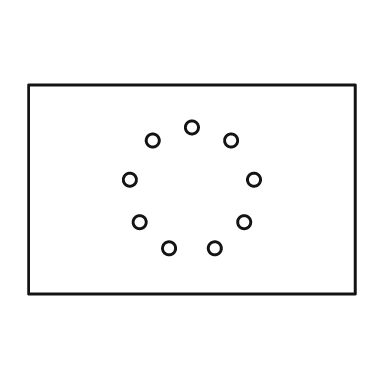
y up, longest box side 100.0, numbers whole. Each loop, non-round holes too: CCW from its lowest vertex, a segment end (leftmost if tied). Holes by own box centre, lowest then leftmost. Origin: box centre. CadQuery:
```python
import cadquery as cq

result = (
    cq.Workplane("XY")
    .moveTo(-50.0, -32.0)
    .lineTo(50.0, -32.0)
    .lineTo(50.0, 32.0)
    .lineTo(-50.0, 32.0)
    .close()
    .moveTo(-7.0, -18.0)
    .circle(2.0)
    .moveTo(7.0, -18.0)
    .circle(2.0)
    .moveTo(-16.0, -10.0)
    .circle(2.0)
    .moveTo(16.0, -10.0)
    .circle(2.0)
    .moveTo(-19.0, 3.0)
    .circle(2.0)
    .moveTo(19.0, 3.0)
    .circle(2.0)
    .moveTo(-12.0, 15.0)
    .circle(2.0)
    .moveTo(12.0, 15.0)
    .circle(2.0)
    .moveTo(0.0, 19.0)
    .circle(2.0)
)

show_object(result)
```